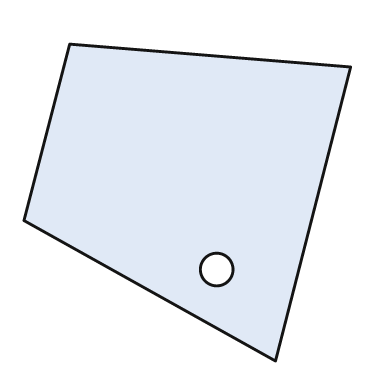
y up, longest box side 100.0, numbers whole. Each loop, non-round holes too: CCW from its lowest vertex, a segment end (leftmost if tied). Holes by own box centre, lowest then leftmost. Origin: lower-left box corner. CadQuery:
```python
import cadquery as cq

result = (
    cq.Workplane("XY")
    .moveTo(77.0, 0.0)
    .lineTo(100.0, 90.0)
    .lineTo(14.0, 97.0)
    .lineTo(0.0, 43.0)
    .close()
    .moveTo(59.0, 28.0)
    .circle(5.0)
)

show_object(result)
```